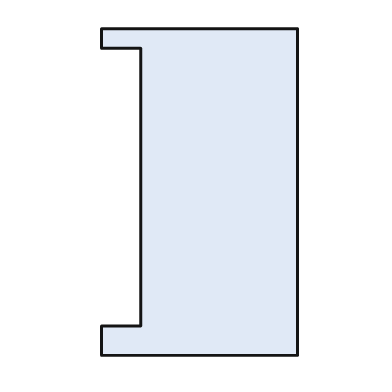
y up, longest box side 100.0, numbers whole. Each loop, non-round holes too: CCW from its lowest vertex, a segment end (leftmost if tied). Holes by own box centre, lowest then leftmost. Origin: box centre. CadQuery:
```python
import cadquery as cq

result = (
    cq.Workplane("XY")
    .moveTo(-30.0, -50.0)
    .lineTo(30.0, -50.0)
    .lineTo(30.0, 50.0)
    .lineTo(-30.0, 50.0)
    .lineTo(-30.0, 44.0)
    .lineTo(-18.0, 44.0)
    .lineTo(-18.0, -41.0)
    .lineTo(-30.0, -41.0)
    .close()
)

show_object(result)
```